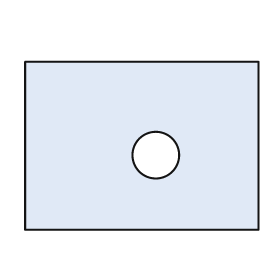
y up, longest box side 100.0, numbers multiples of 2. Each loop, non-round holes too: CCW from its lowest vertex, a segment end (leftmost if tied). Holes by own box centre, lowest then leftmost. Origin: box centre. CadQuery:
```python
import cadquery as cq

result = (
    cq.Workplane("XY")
    .moveTo(-50.0, -36.0)
    .lineTo(50.0, -36.0)
    .lineTo(50.0, 36.0)
    .lineTo(-50.0, 36.0)
    .close()
    .moveTo(6.0, -4.0)
    .circle(10.0)
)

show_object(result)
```